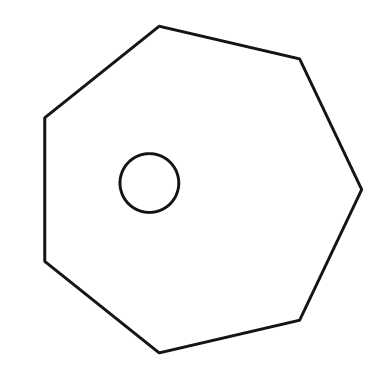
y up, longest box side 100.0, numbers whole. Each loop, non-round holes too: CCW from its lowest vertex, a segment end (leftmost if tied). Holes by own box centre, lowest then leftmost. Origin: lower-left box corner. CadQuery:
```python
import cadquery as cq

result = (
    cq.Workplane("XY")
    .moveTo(35.0, 0.0)
    .lineTo(78.0, 10.0)
    .lineTo(97.0, 50.0)
    .lineTo(78.0, 90.0)
    .lineTo(35.0, 100.0)
    .lineTo(0.0, 72.0)
    .lineTo(0.0, 28.0)
    .close()
    .moveTo(32.0, 52.0)
    .circle(9.0)
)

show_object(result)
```